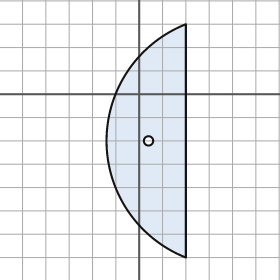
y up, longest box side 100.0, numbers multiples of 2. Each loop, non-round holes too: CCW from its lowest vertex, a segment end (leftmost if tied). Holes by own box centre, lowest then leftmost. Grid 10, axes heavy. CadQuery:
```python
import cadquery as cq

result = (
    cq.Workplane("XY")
    .moveTo(20.0, -70.0)
    .lineTo(20.0, 30.0)
    .threePointArc((-14.0, -20.0), (20.0, -70.0))
    .close()
    .moveTo(4.0, -20.0)
    .circle(2.0)
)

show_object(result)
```